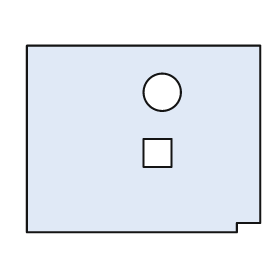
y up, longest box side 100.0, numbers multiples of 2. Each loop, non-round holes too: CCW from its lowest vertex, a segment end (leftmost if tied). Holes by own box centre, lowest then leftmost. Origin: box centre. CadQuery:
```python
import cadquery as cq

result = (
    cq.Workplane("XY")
    .moveTo(-50.0, -40.0)
    .lineTo(40.0, -40.0)
    .lineTo(40.0, -36.0)
    .lineTo(50.0, -36.0)
    .lineTo(50.0, 40.0)
    .lineTo(-50.0, 40.0)
    .close()
    .moveTo(0.0, -12.0)
    .lineTo(12.0, -12.0)
    .lineTo(12.0, 0.0)
    .lineTo(0.0, 0.0)
    .close()
    .moveTo(8.0, 20.0)
    .circle(8.0)
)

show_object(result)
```